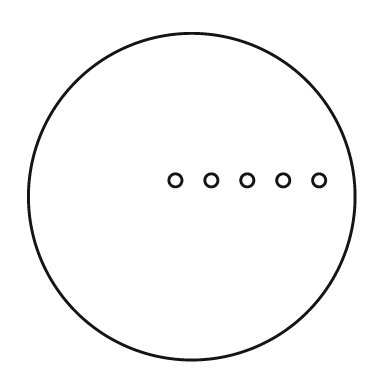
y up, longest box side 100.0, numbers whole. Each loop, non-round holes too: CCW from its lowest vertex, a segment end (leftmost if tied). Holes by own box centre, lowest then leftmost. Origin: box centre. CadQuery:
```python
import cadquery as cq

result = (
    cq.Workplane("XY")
    .moveTo(0.0, 0.0)
    .circle(50.0)
    .moveTo(-5.0, 5.0)
    .circle(2.0)
    .moveTo(6.0, 5.0)
    .circle(2.0)
    .moveTo(17.0, 5.0)
    .circle(2.0)
    .moveTo(28.0, 5.0)
    .circle(2.0)
    .moveTo(39.0, 5.0)
    .circle(2.0)
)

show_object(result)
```